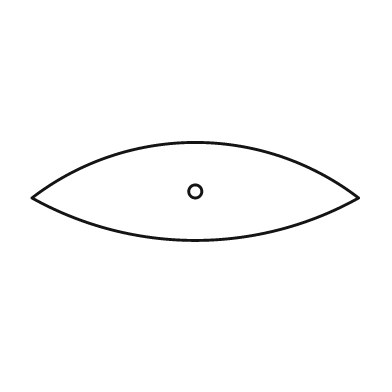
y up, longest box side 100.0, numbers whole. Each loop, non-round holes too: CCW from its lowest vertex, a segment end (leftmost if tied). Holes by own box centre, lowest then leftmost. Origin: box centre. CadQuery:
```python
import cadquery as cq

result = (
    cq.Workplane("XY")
    .moveTo(-50.0, -2.0)
    .threePointArc((0.0, -15.0), (50.0, -2.0))
    .threePointArc((0.0, 15.0), (-50.0, -2.0))
    .close()
    .moveTo(0.0, 0.0)
    .circle(2.0)
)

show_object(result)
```